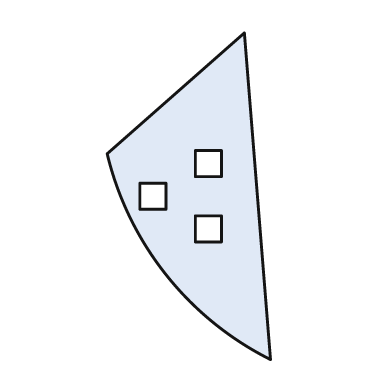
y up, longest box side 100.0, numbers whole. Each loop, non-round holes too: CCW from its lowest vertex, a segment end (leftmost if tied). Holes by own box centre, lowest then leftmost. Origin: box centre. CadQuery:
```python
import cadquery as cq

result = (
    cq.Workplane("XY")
    .moveTo(25.0, -50.0)
    .lineTo(17.0, 50.0)
    .lineTo(-25.0, 13.0)
    .threePointArc((-7.0, -24.0), (25.0, -50.0))
    .close()
    .moveTo(2.0, -14.0)
    .lineTo(10.0, -14.0)
    .lineTo(10.0, -6.0)
    .lineTo(2.0, -6.0)
    .close()
    .moveTo(-15.0, -4.0)
    .lineTo(-7.0, -4.0)
    .lineTo(-7.0, 4.0)
    .lineTo(-15.0, 4.0)
    .close()
    .moveTo(2.0, 6.0)
    .lineTo(10.0, 6.0)
    .lineTo(10.0, 14.0)
    .lineTo(2.0, 14.0)
    .close()
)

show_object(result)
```